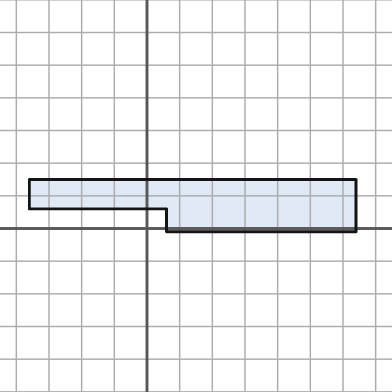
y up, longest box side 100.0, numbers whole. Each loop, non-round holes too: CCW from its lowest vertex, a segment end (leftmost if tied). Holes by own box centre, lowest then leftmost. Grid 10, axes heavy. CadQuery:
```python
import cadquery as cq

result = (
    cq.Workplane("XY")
    .moveTo(6.0, -1.0)
    .lineTo(64.0, -1.0)
    .lineTo(64.0, 15.0)
    .lineTo(-36.0, 15.0)
    .lineTo(-36.0, 6.0)
    .lineTo(6.0, 6.0)
    .close()
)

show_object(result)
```